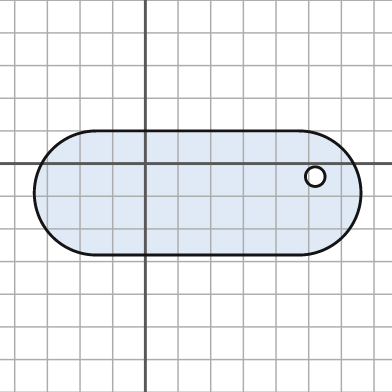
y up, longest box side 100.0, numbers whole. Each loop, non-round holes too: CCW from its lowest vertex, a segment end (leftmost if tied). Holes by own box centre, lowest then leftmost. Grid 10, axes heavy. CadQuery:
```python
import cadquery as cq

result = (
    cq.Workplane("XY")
    .moveTo(-15.0, -28.0)
    .lineTo(47.0, -28.0)
    .threePointArc((66.0, -9.0), (47.0, 10.0))
    .lineTo(-15.0, 10.0)
    .threePointArc((-34.0, -9.0), (-15.0, -28.0))
    .close()
    .moveTo(52.0, -4.0)
    .circle(3.0)
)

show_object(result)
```